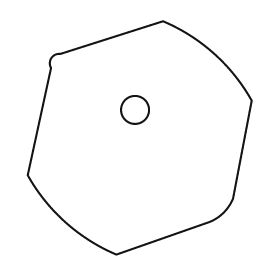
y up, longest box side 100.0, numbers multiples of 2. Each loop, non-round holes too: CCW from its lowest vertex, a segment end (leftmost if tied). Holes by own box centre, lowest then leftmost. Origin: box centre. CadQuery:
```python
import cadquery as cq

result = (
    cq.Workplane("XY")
    .moveTo(-10.0, -50.0)
    .lineTo(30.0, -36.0)
    .threePointArc((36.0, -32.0), (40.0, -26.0))
    .lineTo(48.0, 16.0)
    .threePointArc((32.0, 36.0), (10.0, 50.0))
    .lineTo(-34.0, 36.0)
    .threePointArc((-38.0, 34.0), (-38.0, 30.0))
    .lineTo(-48.0, -16.0)
    .threePointArc((-32.0, -36.0), (-10.0, -50.0))
    .close()
    .moveTo(-2.0, 12.0)
    .circle(6.0)
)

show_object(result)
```